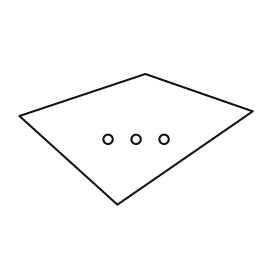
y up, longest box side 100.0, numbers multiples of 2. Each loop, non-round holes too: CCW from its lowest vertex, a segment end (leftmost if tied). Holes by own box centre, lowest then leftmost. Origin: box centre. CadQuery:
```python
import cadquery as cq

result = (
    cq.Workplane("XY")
    .moveTo(-8.0, -28.0)
    .lineTo(50.0, 12.0)
    .lineTo(4.0, 28.0)
    .lineTo(-50.0, 10.0)
    .close()
    .moveTo(-12.0, 0.0)
    .circle(2.0)
    .moveTo(0.0, 0.0)
    .circle(2.0)
    .moveTo(12.0, 0.0)
    .circle(2.0)
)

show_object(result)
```